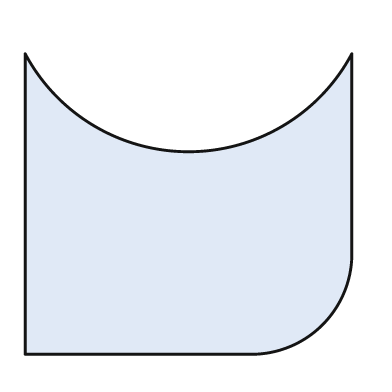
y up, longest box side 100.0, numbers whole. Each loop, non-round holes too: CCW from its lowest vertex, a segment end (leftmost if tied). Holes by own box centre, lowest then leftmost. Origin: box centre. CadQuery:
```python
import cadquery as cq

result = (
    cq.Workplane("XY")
    .moveTo(-50.0, -46.0)
    .lineTo(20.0, -46.0)
    .threePointArc((41.0, -37.0), (50.0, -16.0))
    .lineTo(50.0, 46.0)
    .threePointArc((0.0, 16.0), (-50.0, 46.0))
    .close()
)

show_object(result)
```